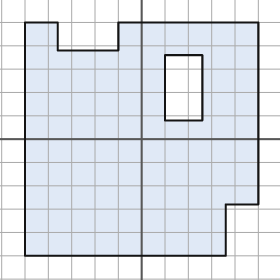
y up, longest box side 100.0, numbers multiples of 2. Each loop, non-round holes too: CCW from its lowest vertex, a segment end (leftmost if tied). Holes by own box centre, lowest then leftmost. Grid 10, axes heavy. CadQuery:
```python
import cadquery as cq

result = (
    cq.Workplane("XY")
    .moveTo(-50.0, -50.0)
    .lineTo(36.0, -50.0)
    .lineTo(36.0, -28.0)
    .lineTo(50.0, -28.0)
    .lineTo(50.0, 50.0)
    .lineTo(-10.0, 50.0)
    .lineTo(-10.0, 38.0)
    .lineTo(-36.0, 38.0)
    .lineTo(-36.0, 50.0)
    .lineTo(-50.0, 50.0)
    .close()
    .moveTo(10.0, 8.0)
    .lineTo(26.0, 8.0)
    .lineTo(26.0, 36.0)
    .lineTo(10.0, 36.0)
    .close()
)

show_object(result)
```